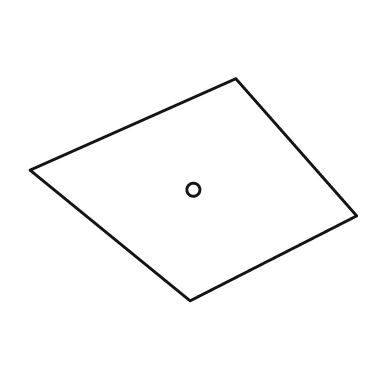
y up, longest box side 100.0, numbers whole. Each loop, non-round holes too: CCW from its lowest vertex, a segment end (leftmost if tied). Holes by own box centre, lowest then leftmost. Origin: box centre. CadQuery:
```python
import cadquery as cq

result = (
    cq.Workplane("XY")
    .moveTo(-1.0, -34.0)
    .lineTo(50.0, -8.0)
    .lineTo(13.0, 34.0)
    .lineTo(-50.0, 6.0)
    .close()
    .moveTo(0.0, 0.0)
    .circle(2.0)
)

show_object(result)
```